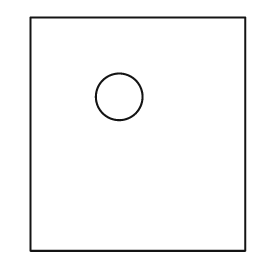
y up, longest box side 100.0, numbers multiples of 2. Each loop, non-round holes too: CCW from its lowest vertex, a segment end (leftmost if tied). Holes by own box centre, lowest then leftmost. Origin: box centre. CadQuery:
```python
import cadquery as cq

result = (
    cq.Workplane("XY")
    .moveTo(-46.0, -50.0)
    .lineTo(46.0, -50.0)
    .lineTo(46.0, 50.0)
    .lineTo(-46.0, 50.0)
    .close()
    .moveTo(-8.0, 16.0)
    .circle(10.0)
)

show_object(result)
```